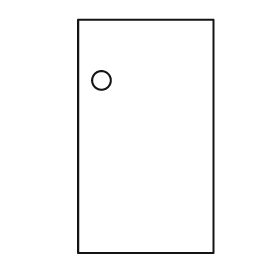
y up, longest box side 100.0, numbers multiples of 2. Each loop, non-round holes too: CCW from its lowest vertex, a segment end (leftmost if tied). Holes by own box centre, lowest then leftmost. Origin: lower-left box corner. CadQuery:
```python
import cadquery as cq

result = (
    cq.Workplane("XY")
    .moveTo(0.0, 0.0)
    .lineTo(58.0, 0.0)
    .lineTo(58.0, 100.0)
    .lineTo(0.0, 100.0)
    .close()
    .moveTo(10.0, 74.0)
    .circle(4.0)
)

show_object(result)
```